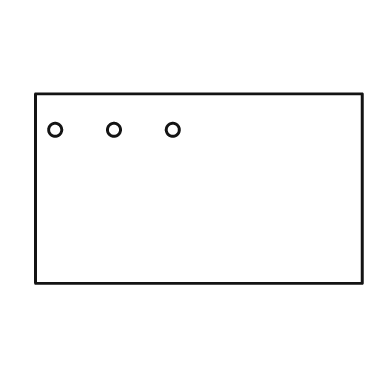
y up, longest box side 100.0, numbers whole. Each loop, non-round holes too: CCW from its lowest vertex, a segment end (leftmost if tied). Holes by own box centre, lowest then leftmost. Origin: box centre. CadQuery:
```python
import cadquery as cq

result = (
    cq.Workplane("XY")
    .moveTo(-50.0, -29.0)
    .lineTo(50.0, -29.0)
    .lineTo(50.0, 29.0)
    .lineTo(-50.0, 29.0)
    .close()
    .moveTo(-44.0, 18.0)
    .circle(2.0)
    .moveTo(-26.0, 18.0)
    .circle(2.0)
    .moveTo(-8.0, 18.0)
    .circle(2.0)
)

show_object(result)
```